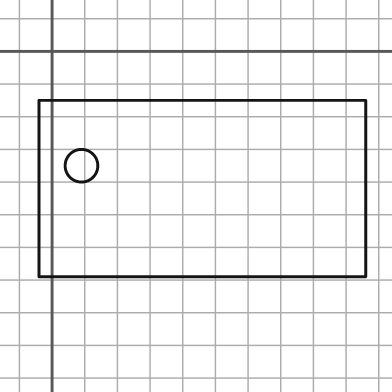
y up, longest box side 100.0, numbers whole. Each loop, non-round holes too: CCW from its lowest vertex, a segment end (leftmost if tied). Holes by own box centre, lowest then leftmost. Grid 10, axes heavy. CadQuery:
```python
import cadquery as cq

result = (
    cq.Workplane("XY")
    .moveTo(-4.0, -69.0)
    .lineTo(96.0, -69.0)
    .lineTo(96.0, -15.0)
    .lineTo(-4.0, -15.0)
    .close()
    .moveTo(9.0, -35.0)
    .circle(5.0)
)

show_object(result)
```